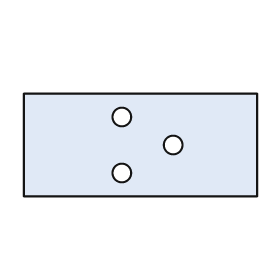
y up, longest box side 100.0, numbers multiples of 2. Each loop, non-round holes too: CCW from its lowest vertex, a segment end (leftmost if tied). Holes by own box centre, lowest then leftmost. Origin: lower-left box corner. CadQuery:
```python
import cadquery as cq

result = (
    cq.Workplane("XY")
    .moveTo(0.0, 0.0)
    .lineTo(100.0, 0.0)
    .lineTo(100.0, 44.0)
    .lineTo(0.0, 44.0)
    .close()
    .moveTo(42.0, 10.0)
    .circle(4.0)
    .moveTo(64.0, 22.0)
    .circle(4.0)
    .moveTo(42.0, 34.0)
    .circle(4.0)
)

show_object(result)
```